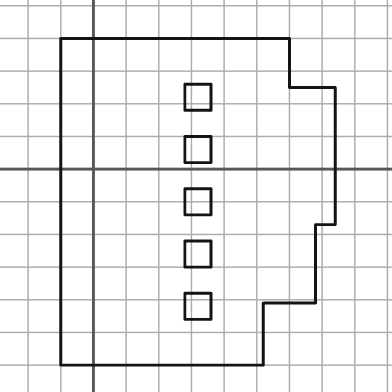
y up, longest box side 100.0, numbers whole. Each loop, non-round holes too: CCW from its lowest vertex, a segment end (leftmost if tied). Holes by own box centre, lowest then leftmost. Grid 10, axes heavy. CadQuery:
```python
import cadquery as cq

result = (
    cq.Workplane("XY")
    .moveTo(-10.0, -60.0)
    .lineTo(52.0, -60.0)
    .lineTo(52.0, -41.0)
    .lineTo(68.0, -41.0)
    .lineTo(68.0, -17.0)
    .lineTo(74.0, -17.0)
    .lineTo(74.0, 25.0)
    .lineTo(60.0, 25.0)
    .lineTo(60.0, 40.0)
    .lineTo(-10.0, 40.0)
    .close()
    .moveTo(28.0, -46.0)
    .lineTo(36.0, -46.0)
    .lineTo(36.0, -38.0)
    .lineTo(28.0, -38.0)
    .close()
    .moveTo(28.0, -30.0)
    .lineTo(36.0, -30.0)
    .lineTo(36.0, -22.0)
    .lineTo(28.0, -22.0)
    .close()
    .moveTo(28.0, -14.0)
    .lineTo(36.0, -14.0)
    .lineTo(36.0, -6.0)
    .lineTo(28.0, -6.0)
    .close()
    .moveTo(28.0, 2.0)
    .lineTo(36.0, 2.0)
    .lineTo(36.0, 10.0)
    .lineTo(28.0, 10.0)
    .close()
    .moveTo(28.0, 18.0)
    .lineTo(36.0, 18.0)
    .lineTo(36.0, 26.0)
    .lineTo(28.0, 26.0)
    .close()
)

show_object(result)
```